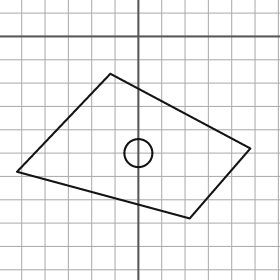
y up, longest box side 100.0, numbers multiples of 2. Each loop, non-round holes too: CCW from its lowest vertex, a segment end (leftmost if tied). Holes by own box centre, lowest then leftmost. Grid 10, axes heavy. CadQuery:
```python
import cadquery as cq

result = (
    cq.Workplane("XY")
    .moveTo(22.0, -78.0)
    .lineTo(48.0, -48.0)
    .lineTo(-12.0, -16.0)
    .lineTo(-52.0, -58.0)
    .close()
    .moveTo(0.0, -50.0)
    .circle(6.0)
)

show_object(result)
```